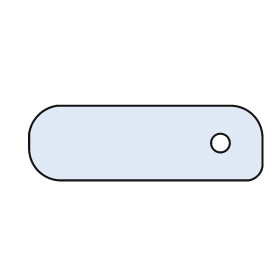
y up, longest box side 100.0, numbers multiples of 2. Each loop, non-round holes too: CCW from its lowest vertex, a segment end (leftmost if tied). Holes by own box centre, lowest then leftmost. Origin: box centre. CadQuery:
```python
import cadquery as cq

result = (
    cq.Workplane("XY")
    .moveTo(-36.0, -16.0)
    .lineTo(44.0, -16.0)
    .threePointArc((48.0, -14.0), (50.0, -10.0))
    .lineTo(50.0, 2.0)
    .threePointArc((46.0, 12.0), (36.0, 16.0))
    .lineTo(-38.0, 16.0)
    .threePointArc((-46.0, 12.0), (-50.0, 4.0))
    .lineTo(-50.0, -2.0)
    .threePointArc((-46.0, -12.0), (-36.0, -16.0))
    .close()
    .moveTo(32.0, 0.0)
    .circle(4.0)
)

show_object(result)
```